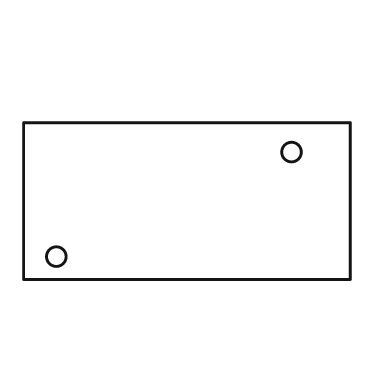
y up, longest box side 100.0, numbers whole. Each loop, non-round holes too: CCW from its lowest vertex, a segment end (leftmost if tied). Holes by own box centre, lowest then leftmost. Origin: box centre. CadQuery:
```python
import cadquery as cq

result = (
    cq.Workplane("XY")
    .moveTo(-50.0, -24.0)
    .lineTo(50.0, -24.0)
    .lineTo(50.0, 24.0)
    .lineTo(-50.0, 24.0)
    .close()
    .moveTo(-40.0, -17.0)
    .circle(3.0)
    .moveTo(32.0, 15.0)
    .circle(3.0)
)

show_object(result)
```